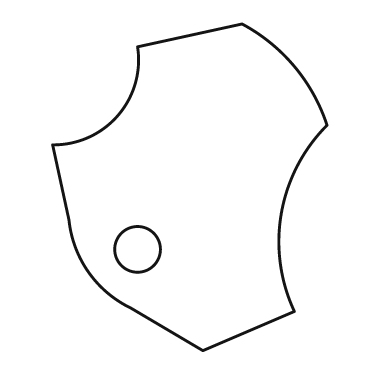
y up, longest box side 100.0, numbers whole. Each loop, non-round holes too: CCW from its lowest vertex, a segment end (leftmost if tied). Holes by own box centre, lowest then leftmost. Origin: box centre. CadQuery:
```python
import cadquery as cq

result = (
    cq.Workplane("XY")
    .moveTo(4.0, -50.0)
    .lineTo(32.0, -38.0)
    .threePointArc((28.0, -8.0), (42.0, 19.0))
    .threePointArc((32.0, 37.0), (16.0, 50.0))
    .lineTo(-16.0, 43.0)
    .threePointArc((-22.0, 22.0), (-42.0, 13.0))
    .lineTo(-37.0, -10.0)
    .threePointArc((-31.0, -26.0), (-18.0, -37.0))
    .close()
    .moveTo(-16.0, -19.0)
    .circle(7.0)
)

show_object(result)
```